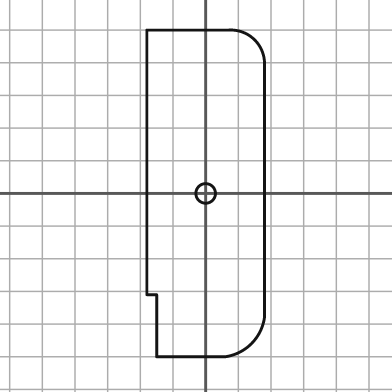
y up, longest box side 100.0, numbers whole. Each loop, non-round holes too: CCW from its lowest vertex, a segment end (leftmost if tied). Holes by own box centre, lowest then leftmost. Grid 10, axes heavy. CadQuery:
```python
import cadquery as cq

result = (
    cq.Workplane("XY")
    .moveTo(-15.0, -50.0)
    .lineTo(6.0, -50.0)
    .threePointArc((14.0, -46.0), (18.0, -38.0))
    .lineTo(18.0, 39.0)
    .threePointArc((15.0, 47.0), (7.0, 50.0))
    .lineTo(-18.0, 50.0)
    .lineTo(-18.0, -31.0)
    .lineTo(-15.0, -31.0)
    .close()
    .moveTo(0.0, 0.0)
    .circle(3.0)
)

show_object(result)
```